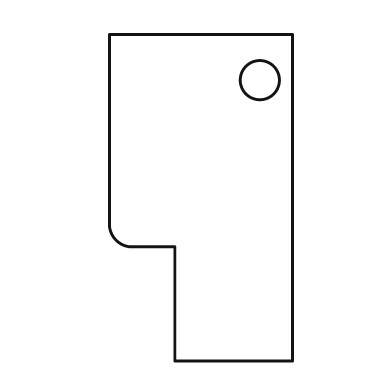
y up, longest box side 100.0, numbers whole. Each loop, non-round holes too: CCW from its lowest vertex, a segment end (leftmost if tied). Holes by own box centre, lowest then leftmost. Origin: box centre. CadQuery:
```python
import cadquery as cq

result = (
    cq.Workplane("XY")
    .moveTo(-8.0, -50.0)
    .lineTo(28.0, -50.0)
    .lineTo(28.0, 50.0)
    .lineTo(-28.0, 50.0)
    .lineTo(-28.0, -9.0)
    .threePointArc((-26.0, -13.0), (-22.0, -15.0))
    .lineTo(-8.0, -15.0)
    .close()
    .moveTo(18.0, 36.0)
    .circle(6.0)
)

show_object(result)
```